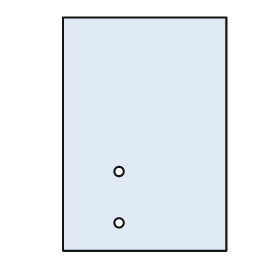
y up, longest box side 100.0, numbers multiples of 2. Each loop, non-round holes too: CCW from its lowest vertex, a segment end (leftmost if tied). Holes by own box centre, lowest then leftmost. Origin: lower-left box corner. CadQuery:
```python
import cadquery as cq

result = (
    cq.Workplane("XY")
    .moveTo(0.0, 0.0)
    .lineTo(70.0, 0.0)
    .lineTo(70.0, 100.0)
    .lineTo(0.0, 100.0)
    .close()
    .moveTo(24.0, 12.0)
    .circle(2.0)
    .moveTo(24.0, 34.0)
    .circle(2.0)
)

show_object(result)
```